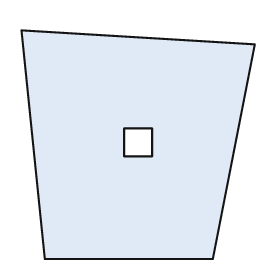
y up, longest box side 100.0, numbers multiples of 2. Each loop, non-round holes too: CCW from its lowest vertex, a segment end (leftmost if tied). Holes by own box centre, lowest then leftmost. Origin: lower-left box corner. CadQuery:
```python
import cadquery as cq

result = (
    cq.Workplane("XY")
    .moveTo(10.0, 0.0)
    .lineTo(82.0, 0.0)
    .lineTo(100.0, 92.0)
    .lineTo(0.0, 98.0)
    .close()
    .moveTo(44.0, 44.0)
    .lineTo(56.0, 44.0)
    .lineTo(56.0, 56.0)
    .lineTo(44.0, 56.0)
    .close()
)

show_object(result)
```